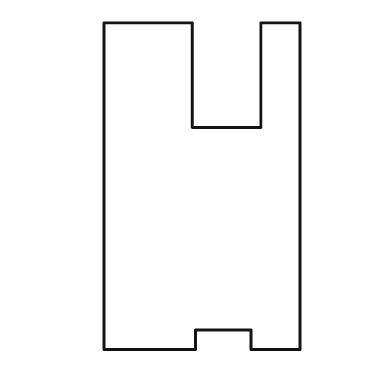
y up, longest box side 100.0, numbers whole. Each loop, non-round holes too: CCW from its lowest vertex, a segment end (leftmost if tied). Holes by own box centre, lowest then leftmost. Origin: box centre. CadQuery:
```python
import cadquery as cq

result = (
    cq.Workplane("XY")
    .moveTo(-30.0, -50.0)
    .lineTo(-2.0, -50.0)
    .lineTo(-2.0, -44.0)
    .lineTo(15.0, -44.0)
    .lineTo(15.0, -50.0)
    .lineTo(30.0, -50.0)
    .lineTo(30.0, 50.0)
    .lineTo(18.0, 50.0)
    .lineTo(18.0, 18.0)
    .lineTo(-3.0, 18.0)
    .lineTo(-3.0, 50.0)
    .lineTo(-30.0, 50.0)
    .close()
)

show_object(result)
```